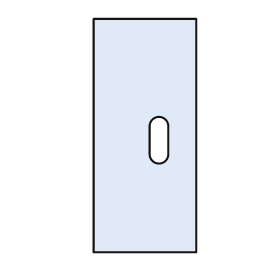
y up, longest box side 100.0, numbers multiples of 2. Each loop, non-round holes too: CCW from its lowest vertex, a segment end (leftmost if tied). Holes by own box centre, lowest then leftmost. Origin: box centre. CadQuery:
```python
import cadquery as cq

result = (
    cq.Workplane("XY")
    .moveTo(-22.0, -50.0)
    .lineTo(22.0, -50.0)
    .lineTo(22.0, 50.0)
    .lineTo(-22.0, 50.0)
    .close()
    .moveTo(2.0, -8.0)
    .threePointArc((6.0, -12.0), (10.0, -8.0))
    .lineTo(10.0, 4.0)
    .threePointArc((6.0, 8.0), (2.0, 4.0))
    .close()
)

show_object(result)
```